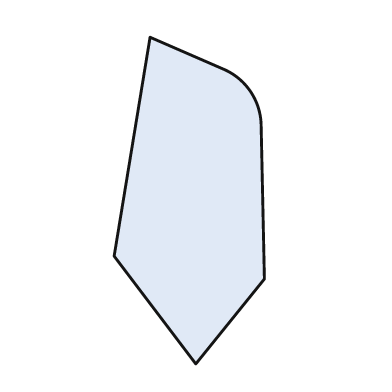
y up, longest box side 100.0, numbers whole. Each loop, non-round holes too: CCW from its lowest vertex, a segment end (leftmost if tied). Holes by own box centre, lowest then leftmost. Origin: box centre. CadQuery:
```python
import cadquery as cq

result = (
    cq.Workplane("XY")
    .moveTo(2.0, -50.0)
    .lineTo(23.0, -24.0)
    .lineTo(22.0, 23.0)
    .threePointArc((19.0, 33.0), (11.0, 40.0))
    .lineTo(-12.0, 50.0)
    .lineTo(-23.0, -17.0)
    .close()
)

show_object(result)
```